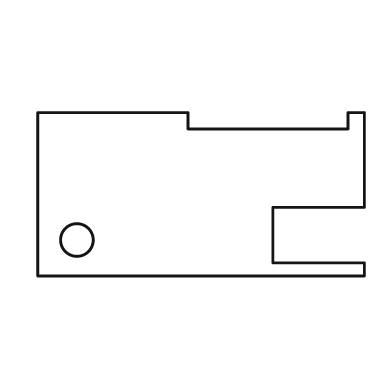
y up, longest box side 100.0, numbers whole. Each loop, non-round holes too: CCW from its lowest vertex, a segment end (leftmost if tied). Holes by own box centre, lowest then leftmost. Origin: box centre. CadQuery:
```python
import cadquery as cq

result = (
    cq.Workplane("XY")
    .moveTo(-50.0, -25.0)
    .lineTo(50.0, -25.0)
    .lineTo(50.0, -21.0)
    .lineTo(22.0, -21.0)
    .lineTo(22.0, -4.0)
    .lineTo(50.0, -4.0)
    .lineTo(50.0, 25.0)
    .lineTo(45.0, 25.0)
    .lineTo(45.0, 20.0)
    .lineTo(-4.0, 20.0)
    .lineTo(-4.0, 25.0)
    .lineTo(-50.0, 25.0)
    .close()
    .moveTo(-38.0, -14.0)
    .circle(5.0)
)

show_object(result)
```